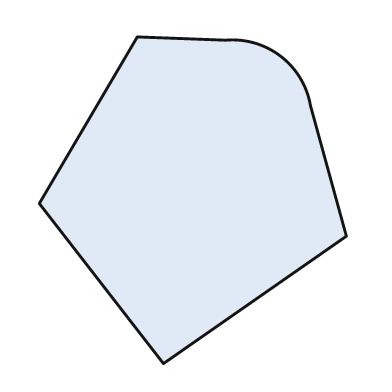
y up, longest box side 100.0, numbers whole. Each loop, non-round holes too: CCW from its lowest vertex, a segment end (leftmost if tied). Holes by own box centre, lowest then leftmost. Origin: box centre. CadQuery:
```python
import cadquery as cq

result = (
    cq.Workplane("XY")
    .moveTo(-9.0, -50.0)
    .lineTo(47.0, -11.0)
    .lineTo(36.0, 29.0)
    .threePointArc((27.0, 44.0), (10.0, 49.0))
    .lineTo(-17.0, 50.0)
    .lineTo(-47.0, -1.0)
    .close()
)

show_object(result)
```